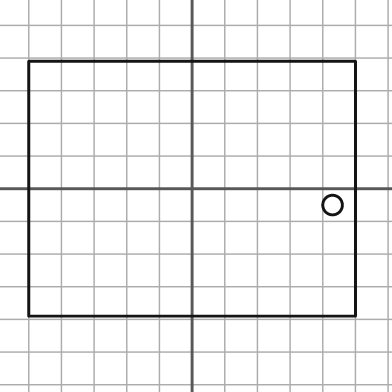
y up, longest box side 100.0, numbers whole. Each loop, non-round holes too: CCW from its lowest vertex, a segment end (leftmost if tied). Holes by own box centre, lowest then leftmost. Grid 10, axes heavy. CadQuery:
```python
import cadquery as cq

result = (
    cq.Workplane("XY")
    .moveTo(-50.0, -39.0)
    .lineTo(50.0, -39.0)
    .lineTo(50.0, 39.0)
    .lineTo(-50.0, 39.0)
    .close()
    .moveTo(43.0, -5.0)
    .circle(3.0)
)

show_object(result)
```